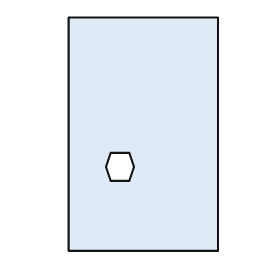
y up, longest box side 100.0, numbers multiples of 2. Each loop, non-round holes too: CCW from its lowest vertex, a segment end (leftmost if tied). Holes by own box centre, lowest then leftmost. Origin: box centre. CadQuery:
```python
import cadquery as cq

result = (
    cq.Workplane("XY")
    .moveTo(-32.0, -50.0)
    .lineTo(32.0, -50.0)
    .lineTo(32.0, 50.0)
    .lineTo(-32.0, 50.0)
    .close()
    .moveTo(-14.0, -20.0)
    .lineTo(-6.0, -20.0)
    .lineTo(-4.0, -14.0)
    .lineTo(-6.0, -8.0)
    .lineTo(-14.0, -8.0)
    .lineTo(-16.0, -14.0)
    .close()
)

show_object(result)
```